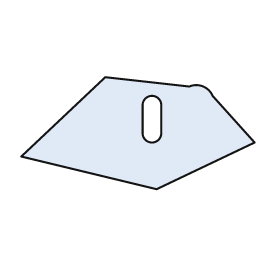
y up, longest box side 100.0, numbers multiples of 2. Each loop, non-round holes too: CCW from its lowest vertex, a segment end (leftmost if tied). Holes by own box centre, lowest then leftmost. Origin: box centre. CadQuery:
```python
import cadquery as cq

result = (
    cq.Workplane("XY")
    .moveTo(8.0, -24.0)
    .lineTo(50.0, -4.0)
    .lineTo(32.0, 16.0)
    .threePointArc((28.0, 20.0), (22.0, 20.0))
    .lineTo(-14.0, 24.0)
    .lineTo(-50.0, -10.0)
    .close()
    .moveTo(2.0, 0.0)
    .threePointArc((6.0, -4.0), (10.0, 0.0))
    .lineTo(10.0, 12.0)
    .threePointArc((6.0, 16.0), (2.0, 12.0))
    .close()
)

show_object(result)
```